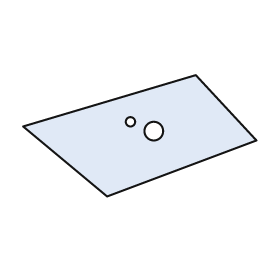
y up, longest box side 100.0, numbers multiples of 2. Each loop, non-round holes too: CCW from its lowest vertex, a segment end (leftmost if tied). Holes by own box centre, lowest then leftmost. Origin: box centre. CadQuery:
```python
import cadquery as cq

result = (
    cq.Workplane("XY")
    .moveTo(-14.0, -26.0)
    .lineTo(50.0, -2.0)
    .lineTo(24.0, 26.0)
    .lineTo(-50.0, 4.0)
    .close()
    .moveTo(6.0, 2.0)
    .circle(4.0)
    .moveTo(-4.0, 6.0)
    .circle(2.0)
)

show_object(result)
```